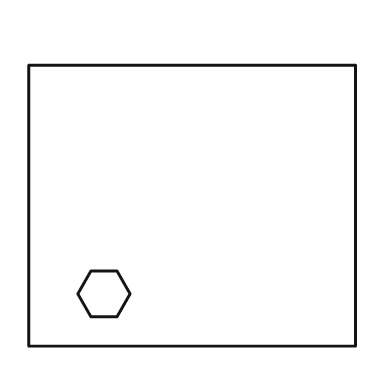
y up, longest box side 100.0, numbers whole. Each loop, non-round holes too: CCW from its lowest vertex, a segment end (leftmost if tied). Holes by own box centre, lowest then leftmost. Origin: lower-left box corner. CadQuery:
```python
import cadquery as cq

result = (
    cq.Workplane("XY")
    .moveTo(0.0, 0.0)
    .lineTo(100.0, 0.0)
    .lineTo(100.0, 86.0)
    .lineTo(0.0, 86.0)
    .close()
    .moveTo(19.0, 9.0)
    .lineTo(27.0, 9.0)
    .lineTo(31.0, 16.0)
    .lineTo(27.0, 23.0)
    .lineTo(19.0, 23.0)
    .lineTo(15.0, 16.0)
    .close()
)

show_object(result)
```